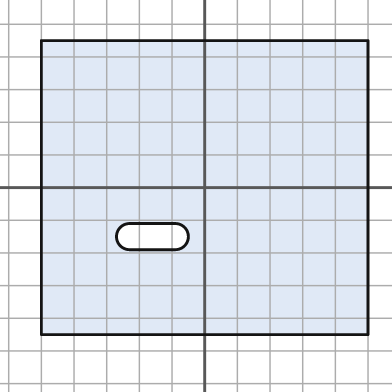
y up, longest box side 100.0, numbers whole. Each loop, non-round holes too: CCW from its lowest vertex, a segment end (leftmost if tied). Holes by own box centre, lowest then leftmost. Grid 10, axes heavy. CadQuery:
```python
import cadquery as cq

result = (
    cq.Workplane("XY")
    .moveTo(-50.0, -45.0)
    .lineTo(50.0, -45.0)
    .lineTo(50.0, 45.0)
    .lineTo(-50.0, 45.0)
    .close()
    .moveTo(-23.0, -19.0)
    .lineTo(-9.0, -19.0)
    .threePointArc((-5.0, -15.0), (-9.0, -11.0))
    .lineTo(-23.0, -11.0)
    .threePointArc((-27.0, -15.0), (-23.0, -19.0))
    .close()
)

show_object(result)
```